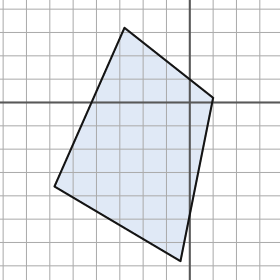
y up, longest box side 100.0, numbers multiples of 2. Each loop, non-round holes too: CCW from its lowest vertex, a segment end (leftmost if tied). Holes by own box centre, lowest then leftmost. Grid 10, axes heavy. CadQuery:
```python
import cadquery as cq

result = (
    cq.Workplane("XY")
    .moveTo(-4.0, -68.0)
    .lineTo(10.0, 2.0)
    .lineTo(-28.0, 32.0)
    .lineTo(-58.0, -36.0)
    .close()
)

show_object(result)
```